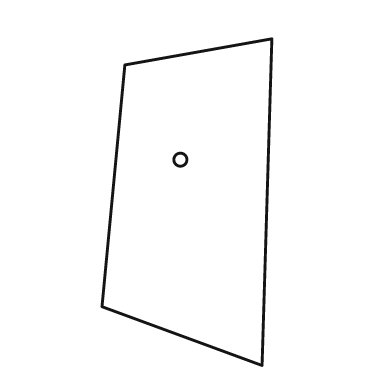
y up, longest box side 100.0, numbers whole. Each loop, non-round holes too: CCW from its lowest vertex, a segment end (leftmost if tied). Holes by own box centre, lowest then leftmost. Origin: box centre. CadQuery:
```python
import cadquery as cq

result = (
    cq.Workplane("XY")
    .moveTo(23.0, -50.0)
    .lineTo(26.0, 50.0)
    .lineTo(-19.0, 42.0)
    .lineTo(-26.0, -32.0)
    .close()
    .moveTo(-2.0, 13.0)
    .circle(2.0)
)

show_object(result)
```